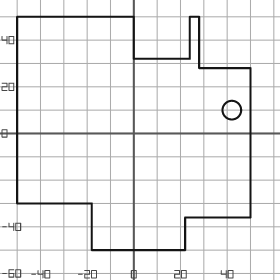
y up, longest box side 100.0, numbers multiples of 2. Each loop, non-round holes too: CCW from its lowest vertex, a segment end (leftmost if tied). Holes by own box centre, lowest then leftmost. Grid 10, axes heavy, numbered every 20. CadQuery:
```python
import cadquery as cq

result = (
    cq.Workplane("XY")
    .moveTo(-18.0, -50.0)
    .lineTo(22.0, -50.0)
    .lineTo(22.0, -36.0)
    .lineTo(50.0, -36.0)
    .lineTo(50.0, 28.0)
    .lineTo(28.0, 28.0)
    .lineTo(28.0, 50.0)
    .lineTo(24.0, 50.0)
    .lineTo(24.0, 32.0)
    .lineTo(0.0, 32.0)
    .lineTo(0.0, 50.0)
    .lineTo(-50.0, 50.0)
    .lineTo(-50.0, -30.0)
    .lineTo(-18.0, -30.0)
    .close()
    .moveTo(42.0, 10.0)
    .circle(4.0)
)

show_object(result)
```